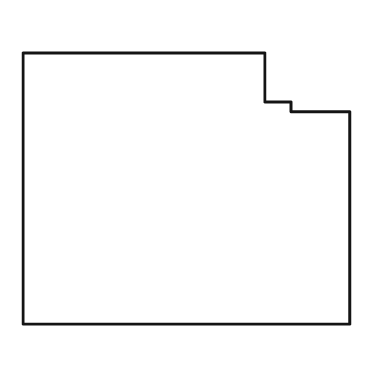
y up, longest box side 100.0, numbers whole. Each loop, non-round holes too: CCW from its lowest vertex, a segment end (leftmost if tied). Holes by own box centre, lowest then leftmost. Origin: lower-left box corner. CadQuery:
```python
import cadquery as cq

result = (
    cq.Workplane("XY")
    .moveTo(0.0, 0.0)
    .lineTo(100.0, 0.0)
    .lineTo(100.0, 65.0)
    .lineTo(82.0, 65.0)
    .lineTo(82.0, 68.0)
    .lineTo(74.0, 68.0)
    .lineTo(74.0, 83.0)
    .lineTo(0.0, 83.0)
    .close()
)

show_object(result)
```